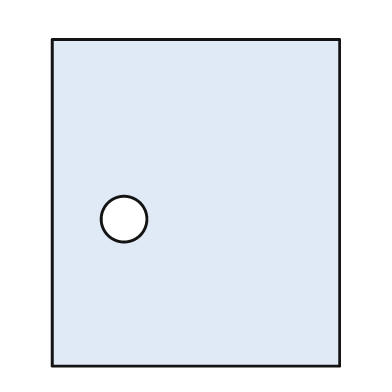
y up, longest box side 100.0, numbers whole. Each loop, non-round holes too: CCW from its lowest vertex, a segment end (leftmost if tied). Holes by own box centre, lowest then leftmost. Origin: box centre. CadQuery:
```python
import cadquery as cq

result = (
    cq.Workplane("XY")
    .moveTo(-44.0, -50.0)
    .lineTo(44.0, -50.0)
    .lineTo(44.0, 50.0)
    .lineTo(-44.0, 50.0)
    .close()
    .moveTo(-22.0, -5.0)
    .circle(7.0)
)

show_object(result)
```